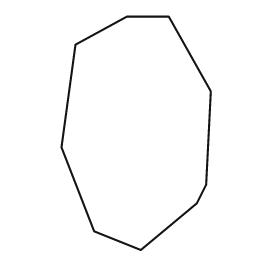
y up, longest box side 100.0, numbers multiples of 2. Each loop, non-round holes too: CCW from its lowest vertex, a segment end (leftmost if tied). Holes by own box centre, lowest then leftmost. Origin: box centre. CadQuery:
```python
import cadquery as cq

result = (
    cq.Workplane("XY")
    .moveTo(2.0, -50.0)
    .lineTo(26.0, -30.0)
    .lineTo(30.0, -22.0)
    .lineTo(32.0, 18.0)
    .lineTo(14.0, 50.0)
    .lineTo(-4.0, 50.0)
    .lineTo(-26.0, 38.0)
    .lineTo(-32.0, -6.0)
    .lineTo(-18.0, -42.0)
    .close()
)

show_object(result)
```